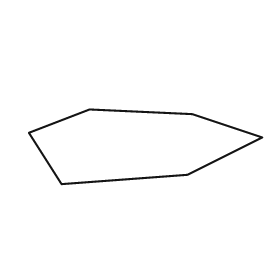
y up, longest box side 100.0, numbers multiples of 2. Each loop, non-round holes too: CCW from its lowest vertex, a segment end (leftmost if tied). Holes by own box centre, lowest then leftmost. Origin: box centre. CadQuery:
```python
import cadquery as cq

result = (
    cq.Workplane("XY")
    .moveTo(-36.0, -16.0)
    .lineTo(18.0, -12.0)
    .lineTo(50.0, 4.0)
    .lineTo(20.0, 14.0)
    .lineTo(-24.0, 16.0)
    .lineTo(-50.0, 6.0)
    .close()
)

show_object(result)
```